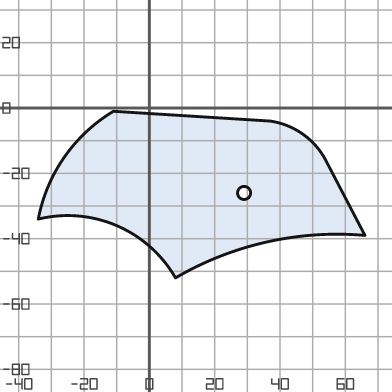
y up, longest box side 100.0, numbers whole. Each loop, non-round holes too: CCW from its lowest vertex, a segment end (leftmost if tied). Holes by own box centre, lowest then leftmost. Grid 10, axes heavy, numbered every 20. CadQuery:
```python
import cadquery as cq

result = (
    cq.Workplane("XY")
    .moveTo(8.0, -52.0)
    .threePointArc((36.0, -41.0), (66.0, -39.0))
    .lineTo(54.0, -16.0)
    .threePointArc((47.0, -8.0), (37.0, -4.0))
    .lineTo(-11.0, -1.0)
    .threePointArc((-26.0, -15.0), (-34.0, -34.0))
    .threePointArc((-10.0, -36.0), (8.0, -52.0))
    .close()
    .moveTo(29.0, -26.0)
    .circle(2.0)
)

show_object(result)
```